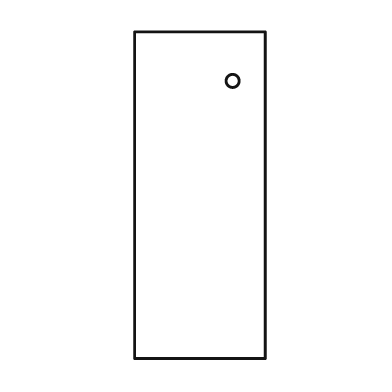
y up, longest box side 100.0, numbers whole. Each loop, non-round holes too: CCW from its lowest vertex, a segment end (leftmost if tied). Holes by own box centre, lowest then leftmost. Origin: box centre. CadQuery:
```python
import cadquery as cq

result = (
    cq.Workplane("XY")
    .moveTo(-20.0, -50.0)
    .lineTo(20.0, -50.0)
    .lineTo(20.0, 50.0)
    .lineTo(-20.0, 50.0)
    .close()
    .moveTo(10.0, 35.0)
    .circle(2.0)
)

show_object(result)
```